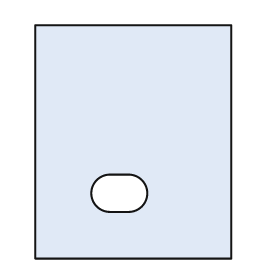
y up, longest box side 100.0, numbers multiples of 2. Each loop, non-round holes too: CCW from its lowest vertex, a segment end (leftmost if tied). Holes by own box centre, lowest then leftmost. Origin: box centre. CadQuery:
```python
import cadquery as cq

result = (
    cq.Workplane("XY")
    .moveTo(-42.0, -50.0)
    .lineTo(42.0, -50.0)
    .lineTo(42.0, 50.0)
    .lineTo(-42.0, 50.0)
    .close()
    .moveTo(-10.0, -30.0)
    .lineTo(-2.0, -30.0)
    .threePointArc((6.0, -22.0), (-2.0, -14.0))
    .lineTo(-10.0, -14.0)
    .threePointArc((-18.0, -22.0), (-10.0, -30.0))
    .close()
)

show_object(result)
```